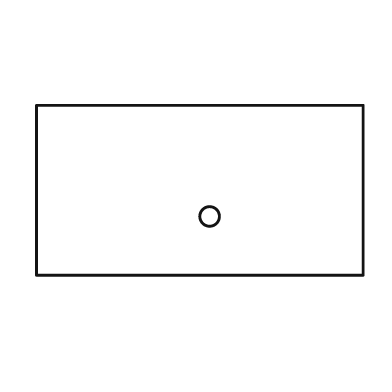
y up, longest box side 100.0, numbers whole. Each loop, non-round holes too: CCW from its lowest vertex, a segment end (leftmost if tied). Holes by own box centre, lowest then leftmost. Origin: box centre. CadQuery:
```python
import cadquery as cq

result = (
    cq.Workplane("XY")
    .moveTo(-50.0, -26.0)
    .lineTo(50.0, -26.0)
    .lineTo(50.0, 26.0)
    .lineTo(-50.0, 26.0)
    .close()
    .moveTo(3.0, -8.0)
    .circle(3.0)
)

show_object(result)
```